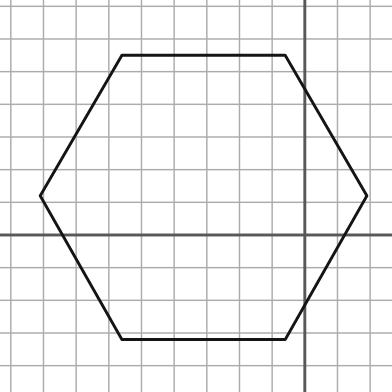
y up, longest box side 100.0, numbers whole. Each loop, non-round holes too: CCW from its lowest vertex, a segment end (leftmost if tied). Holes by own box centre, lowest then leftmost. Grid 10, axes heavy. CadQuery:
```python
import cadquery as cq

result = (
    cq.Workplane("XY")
    .moveTo(-56.0, -32.0)
    .lineTo(-6.0, -32.0)
    .lineTo(19.0, 12.0)
    .lineTo(-6.0, 55.0)
    .lineTo(-56.0, 55.0)
    .lineTo(-81.0, 12.0)
    .close()
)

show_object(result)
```